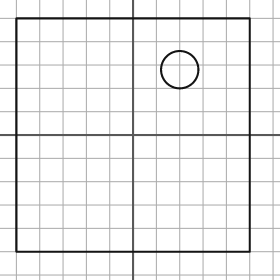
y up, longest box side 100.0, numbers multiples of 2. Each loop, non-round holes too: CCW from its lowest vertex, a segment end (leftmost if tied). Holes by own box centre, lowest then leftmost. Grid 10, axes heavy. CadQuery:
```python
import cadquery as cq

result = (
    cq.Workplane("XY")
    .moveTo(-50.0, -50.0)
    .lineTo(50.0, -50.0)
    .lineTo(50.0, 50.0)
    .lineTo(-50.0, 50.0)
    .close()
    .moveTo(20.0, 28.0)
    .circle(8.0)
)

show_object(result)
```